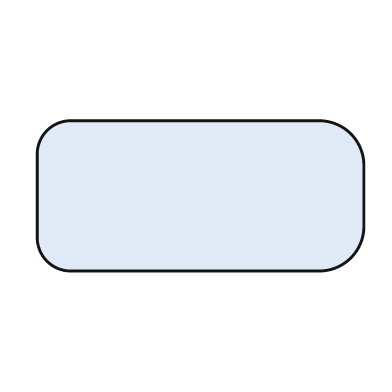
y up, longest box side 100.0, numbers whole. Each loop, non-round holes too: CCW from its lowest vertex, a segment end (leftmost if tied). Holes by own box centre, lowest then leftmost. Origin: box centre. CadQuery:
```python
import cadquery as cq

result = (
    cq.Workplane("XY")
    .moveTo(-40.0, -23.0)
    .lineTo(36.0, -23.0)
    .threePointArc((46.0, -19.0), (50.0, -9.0))
    .lineTo(50.0, 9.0)
    .threePointArc((46.0, 19.0), (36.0, 23.0))
    .lineTo(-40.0, 23.0)
    .threePointArc((-47.0, 20.0), (-50.0, 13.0))
    .lineTo(-50.0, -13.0)
    .threePointArc((-47.0, -20.0), (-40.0, -23.0))
    .close()
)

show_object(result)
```